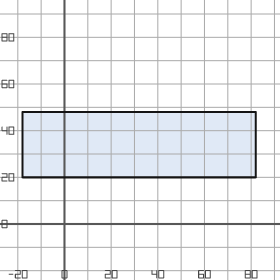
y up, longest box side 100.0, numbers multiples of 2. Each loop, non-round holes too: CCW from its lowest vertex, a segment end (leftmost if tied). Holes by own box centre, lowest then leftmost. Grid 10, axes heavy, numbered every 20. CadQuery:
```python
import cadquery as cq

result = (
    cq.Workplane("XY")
    .moveTo(-18.0, 20.0)
    .lineTo(82.0, 20.0)
    .lineTo(82.0, 48.0)
    .lineTo(-18.0, 48.0)
    .close()
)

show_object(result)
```